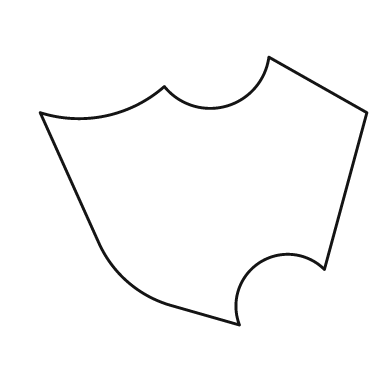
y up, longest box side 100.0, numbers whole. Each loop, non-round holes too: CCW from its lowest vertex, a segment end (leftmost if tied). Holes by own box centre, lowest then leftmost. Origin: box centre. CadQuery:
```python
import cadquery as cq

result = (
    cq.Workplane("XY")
    .moveTo(11.0, -41.0)
    .threePointArc((17.0, -22.0), (37.0, -24.0))
    .lineTo(50.0, 24.0)
    .lineTo(20.0, 41.0)
    .threePointArc((7.0, 26.0), (-12.0, 32.0))
    .threePointArc((-30.0, 23.0), (-50.0, 24.0))
    .lineTo(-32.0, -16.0)
    .threePointArc((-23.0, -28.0), (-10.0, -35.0))
    .close()
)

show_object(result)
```